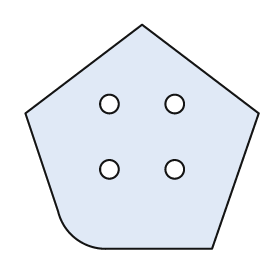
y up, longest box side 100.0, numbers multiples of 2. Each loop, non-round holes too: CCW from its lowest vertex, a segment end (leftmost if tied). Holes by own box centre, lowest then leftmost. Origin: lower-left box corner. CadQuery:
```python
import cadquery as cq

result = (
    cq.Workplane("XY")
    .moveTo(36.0, 0.0)
    .lineTo(80.0, 0.0)
    .lineTo(100.0, 58.0)
    .lineTo(50.0, 96.0)
    .lineTo(0.0, 58.0)
    .lineTo(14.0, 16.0)
    .threePointArc((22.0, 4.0), (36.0, 0.0))
    .close()
    .moveTo(36.0, 34.0)
    .circle(4.0)
    .moveTo(64.0, 34.0)
    .circle(4.0)
    .moveTo(36.0, 62.0)
    .circle(4.0)
    .moveTo(64.0, 62.0)
    .circle(4.0)
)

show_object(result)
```